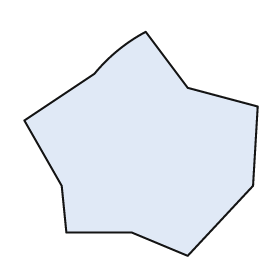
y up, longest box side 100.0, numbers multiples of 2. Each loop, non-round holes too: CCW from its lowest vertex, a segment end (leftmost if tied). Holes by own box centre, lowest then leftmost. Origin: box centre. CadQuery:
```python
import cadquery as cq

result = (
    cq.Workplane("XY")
    .moveTo(20.0, -48.0)
    .lineTo(48.0, -18.0)
    .lineTo(50.0, 16.0)
    .lineTo(20.0, 24.0)
    .lineTo(2.0, 48.0)
    .threePointArc((-10.0, 40.0), (-20.0, 30.0))
    .lineTo(-50.0, 10.0)
    .lineTo(-34.0, -18.0)
    .lineTo(-32.0, -38.0)
    .lineTo(-4.0, -38.0)
    .close()
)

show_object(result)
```